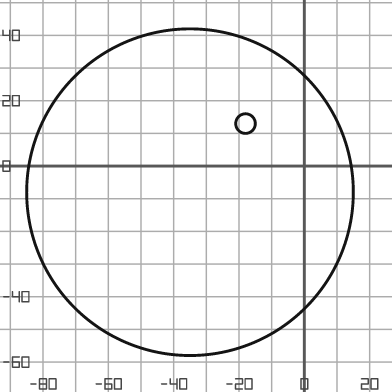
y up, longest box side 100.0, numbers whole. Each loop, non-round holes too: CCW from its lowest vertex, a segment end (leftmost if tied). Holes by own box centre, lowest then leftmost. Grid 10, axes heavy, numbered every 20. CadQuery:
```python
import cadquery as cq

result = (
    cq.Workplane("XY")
    .moveTo(-35.0, -8.0)
    .circle(50.0)
    .moveTo(-18.0, 13.0)
    .circle(3.0)
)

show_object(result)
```